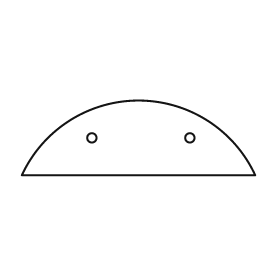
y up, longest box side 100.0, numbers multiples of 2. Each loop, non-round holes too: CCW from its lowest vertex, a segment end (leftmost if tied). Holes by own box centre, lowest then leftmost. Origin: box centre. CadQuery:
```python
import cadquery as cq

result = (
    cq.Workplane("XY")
    .moveTo(-50.0, -16.0)
    .lineTo(50.0, -16.0)
    .threePointArc((0.0, 16.0), (-50.0, -16.0))
    .close()
    .moveTo(-20.0, 0.0)
    .circle(2.0)
    .moveTo(22.0, 0.0)
    .circle(2.0)
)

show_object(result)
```